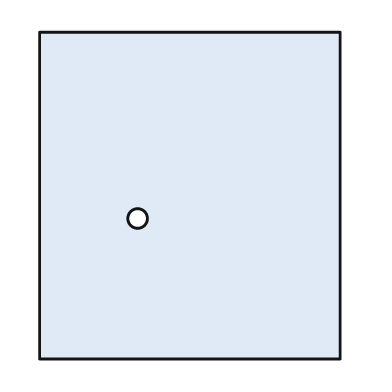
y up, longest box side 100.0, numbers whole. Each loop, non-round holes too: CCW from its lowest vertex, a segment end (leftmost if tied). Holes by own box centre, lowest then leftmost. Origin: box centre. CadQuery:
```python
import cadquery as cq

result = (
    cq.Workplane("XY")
    .moveTo(-46.0, -50.0)
    .lineTo(46.0, -50.0)
    .lineTo(46.0, 50.0)
    .lineTo(-46.0, 50.0)
    .close()
    .moveTo(-16.0, -7.0)
    .circle(3.0)
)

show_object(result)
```